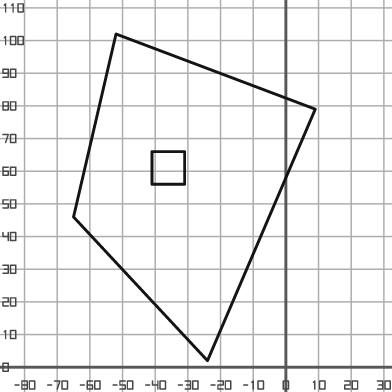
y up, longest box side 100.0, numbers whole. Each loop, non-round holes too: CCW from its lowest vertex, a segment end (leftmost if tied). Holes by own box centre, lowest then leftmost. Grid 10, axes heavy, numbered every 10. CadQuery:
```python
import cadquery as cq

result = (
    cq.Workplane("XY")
    .moveTo(-24.0, 2.0)
    .lineTo(9.0, 79.0)
    .lineTo(-52.0, 102.0)
    .lineTo(-65.0, 46.0)
    .close()
    .moveTo(-41.0, 56.0)
    .lineTo(-31.0, 56.0)
    .lineTo(-31.0, 66.0)
    .lineTo(-41.0, 66.0)
    .close()
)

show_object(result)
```